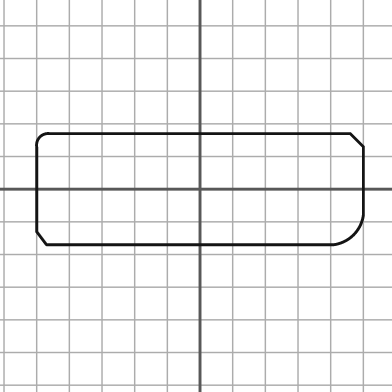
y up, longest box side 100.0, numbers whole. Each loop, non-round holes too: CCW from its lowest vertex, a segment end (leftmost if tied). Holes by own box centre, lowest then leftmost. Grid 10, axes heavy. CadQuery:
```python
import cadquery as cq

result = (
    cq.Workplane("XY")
    .moveTo(-47.0, -17.0)
    .lineTo(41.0, -17.0)
    .threePointArc((47.0, -14.0), (50.0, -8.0))
    .lineTo(50.0, 13.0)
    .lineTo(46.0, 17.0)
    .lineTo(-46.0, 17.0)
    .threePointArc((-49.0, 16.0), (-50.0, 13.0))
    .lineTo(-50.0, -13.0)
    .close()
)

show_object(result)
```